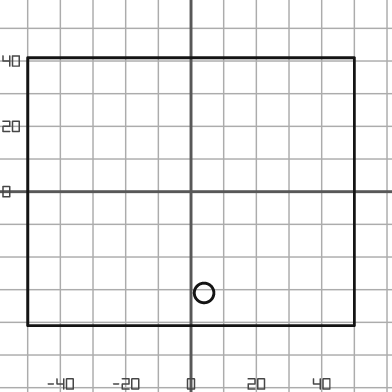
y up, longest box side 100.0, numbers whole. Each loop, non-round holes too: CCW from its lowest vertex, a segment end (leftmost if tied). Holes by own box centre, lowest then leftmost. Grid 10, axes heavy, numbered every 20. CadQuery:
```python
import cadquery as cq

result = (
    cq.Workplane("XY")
    .moveTo(-50.0, -41.0)
    .lineTo(50.0, -41.0)
    .lineTo(50.0, 41.0)
    .lineTo(-50.0, 41.0)
    .close()
    .moveTo(4.0, -31.0)
    .circle(3.0)
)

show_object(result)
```